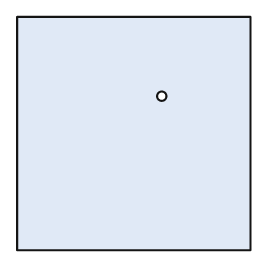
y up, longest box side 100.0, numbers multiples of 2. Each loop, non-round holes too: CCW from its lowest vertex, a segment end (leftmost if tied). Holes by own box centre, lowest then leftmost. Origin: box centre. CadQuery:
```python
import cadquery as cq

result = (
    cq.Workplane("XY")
    .moveTo(-50.0, -50.0)
    .lineTo(50.0, -50.0)
    .lineTo(50.0, 50.0)
    .lineTo(-50.0, 50.0)
    .close()
    .moveTo(12.0, 16.0)
    .circle(2.0)
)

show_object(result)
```